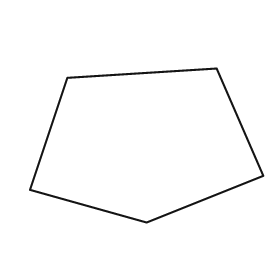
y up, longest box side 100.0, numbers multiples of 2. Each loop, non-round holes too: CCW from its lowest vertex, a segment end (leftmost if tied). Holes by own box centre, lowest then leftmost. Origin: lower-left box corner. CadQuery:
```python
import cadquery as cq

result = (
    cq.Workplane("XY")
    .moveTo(50.0, 0.0)
    .lineTo(100.0, 20.0)
    .lineTo(80.0, 66.0)
    .lineTo(16.0, 62.0)
    .lineTo(0.0, 14.0)
    .close()
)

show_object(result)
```